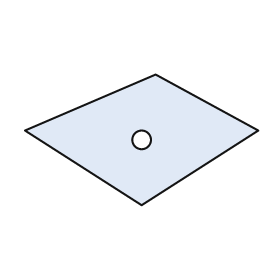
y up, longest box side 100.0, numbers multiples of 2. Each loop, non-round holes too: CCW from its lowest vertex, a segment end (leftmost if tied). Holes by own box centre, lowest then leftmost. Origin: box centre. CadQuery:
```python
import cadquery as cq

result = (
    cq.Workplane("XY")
    .moveTo(0.0, -28.0)
    .lineTo(50.0, 4.0)
    .lineTo(6.0, 28.0)
    .lineTo(-50.0, 4.0)
    .close()
    .moveTo(0.0, 0.0)
    .circle(4.0)
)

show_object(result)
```